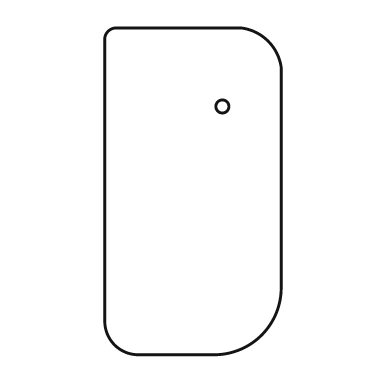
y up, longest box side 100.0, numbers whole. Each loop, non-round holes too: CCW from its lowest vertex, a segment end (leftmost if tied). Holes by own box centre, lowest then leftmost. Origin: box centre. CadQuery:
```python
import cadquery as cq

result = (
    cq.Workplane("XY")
    .moveTo(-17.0, -50.0)
    .lineTo(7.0, -50.0)
    .threePointArc((21.0, -44.0), (27.0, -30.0))
    .lineTo(27.0, 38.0)
    .threePointArc((23.0, 46.0), (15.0, 50.0))
    .lineTo(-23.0, 50.0)
    .threePointArc((-26.0, 49.0), (-27.0, 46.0))
    .lineTo(-27.0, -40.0)
    .threePointArc((-24.0, -47.0), (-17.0, -50.0))
    .close()
    .moveTo(9.0, 26.0)
    .circle(2.0)
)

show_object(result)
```